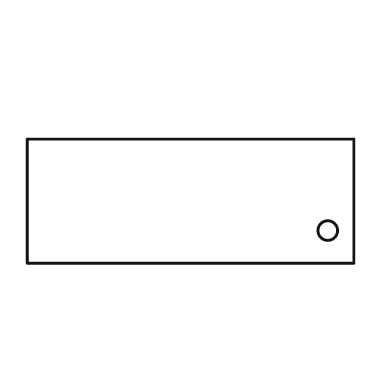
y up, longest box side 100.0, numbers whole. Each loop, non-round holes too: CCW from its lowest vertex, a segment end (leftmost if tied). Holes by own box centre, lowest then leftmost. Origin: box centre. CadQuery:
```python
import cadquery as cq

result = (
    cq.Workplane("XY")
    .moveTo(-50.0, -19.0)
    .lineTo(50.0, -19.0)
    .lineTo(50.0, 19.0)
    .lineTo(-50.0, 19.0)
    .close()
    .moveTo(42.0, -9.0)
    .circle(3.0)
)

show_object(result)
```